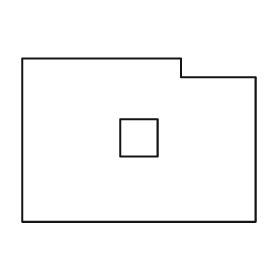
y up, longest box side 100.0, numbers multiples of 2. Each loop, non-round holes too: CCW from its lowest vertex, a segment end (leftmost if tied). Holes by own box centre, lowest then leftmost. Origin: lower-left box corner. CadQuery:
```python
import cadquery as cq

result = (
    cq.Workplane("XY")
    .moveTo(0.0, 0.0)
    .lineTo(100.0, 0.0)
    .lineTo(100.0, 62.0)
    .lineTo(68.0, 62.0)
    .lineTo(68.0, 70.0)
    .lineTo(0.0, 70.0)
    .close()
    .moveTo(42.0, 28.0)
    .lineTo(58.0, 28.0)
    .lineTo(58.0, 44.0)
    .lineTo(42.0, 44.0)
    .close()
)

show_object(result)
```